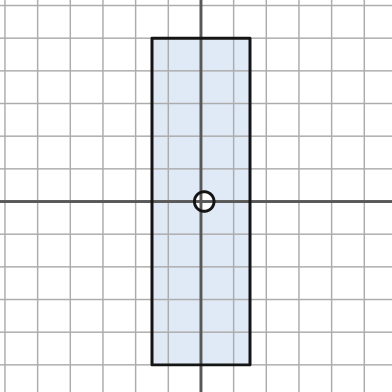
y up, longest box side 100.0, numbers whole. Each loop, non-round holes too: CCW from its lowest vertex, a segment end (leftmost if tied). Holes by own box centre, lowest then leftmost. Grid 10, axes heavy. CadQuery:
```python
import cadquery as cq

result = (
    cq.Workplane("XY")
    .moveTo(-15.0, -50.0)
    .lineTo(15.0, -50.0)
    .lineTo(15.0, 50.0)
    .lineTo(-15.0, 50.0)
    .close()
    .moveTo(1.0, 0.0)
    .circle(3.0)
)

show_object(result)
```